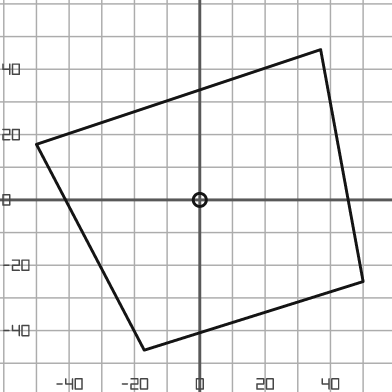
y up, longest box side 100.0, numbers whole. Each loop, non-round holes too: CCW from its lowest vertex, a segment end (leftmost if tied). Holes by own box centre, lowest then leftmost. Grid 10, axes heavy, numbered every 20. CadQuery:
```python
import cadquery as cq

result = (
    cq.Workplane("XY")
    .moveTo(-17.0, -46.0)
    .lineTo(50.0, -25.0)
    .lineTo(37.0, 46.0)
    .lineTo(-50.0, 17.0)
    .close()
    .moveTo(0.0, 0.0)
    .circle(2.0)
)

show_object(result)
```